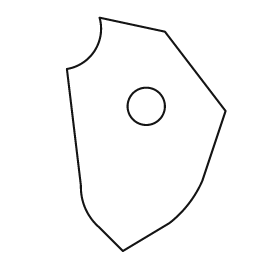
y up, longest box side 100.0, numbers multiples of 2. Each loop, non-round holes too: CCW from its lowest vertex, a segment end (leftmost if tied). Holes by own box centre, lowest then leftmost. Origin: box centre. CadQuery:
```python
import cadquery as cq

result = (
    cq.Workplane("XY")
    .moveTo(-10.0, -50.0)
    .lineTo(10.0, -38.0)
    .threePointArc((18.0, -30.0), (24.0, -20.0))
    .lineTo(34.0, 10.0)
    .lineTo(8.0, 44.0)
    .lineTo(-20.0, 50.0)
    .threePointArc((-22.0, 36.0), (-34.0, 28.0))
    .lineTo(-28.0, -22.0)
    .threePointArc((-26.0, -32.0), (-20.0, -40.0))
    .close()
    .moveTo(0.0, 12.0)
    .circle(8.0)
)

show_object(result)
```